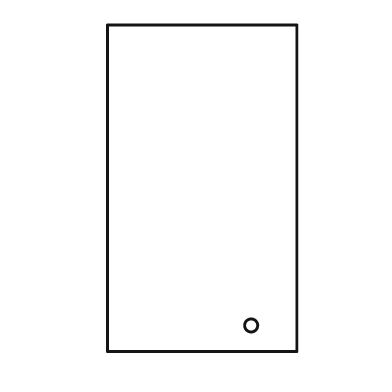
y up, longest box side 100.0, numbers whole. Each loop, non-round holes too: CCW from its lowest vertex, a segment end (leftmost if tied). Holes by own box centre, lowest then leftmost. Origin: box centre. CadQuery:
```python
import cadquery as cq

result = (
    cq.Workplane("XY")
    .moveTo(-29.0, -50.0)
    .lineTo(29.0, -50.0)
    .lineTo(29.0, 50.0)
    .lineTo(-29.0, 50.0)
    .close()
    .moveTo(15.0, -42.0)
    .circle(2.0)
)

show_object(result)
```